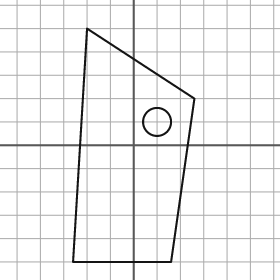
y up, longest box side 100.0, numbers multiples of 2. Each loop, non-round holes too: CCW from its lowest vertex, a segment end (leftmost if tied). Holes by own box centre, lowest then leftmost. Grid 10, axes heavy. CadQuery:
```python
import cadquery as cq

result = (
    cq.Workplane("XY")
    .moveTo(-26.0, -50.0)
    .lineTo(16.0, -50.0)
    .lineTo(26.0, 20.0)
    .lineTo(-20.0, 50.0)
    .close()
    .moveTo(10.0, 10.0)
    .circle(6.0)
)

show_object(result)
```